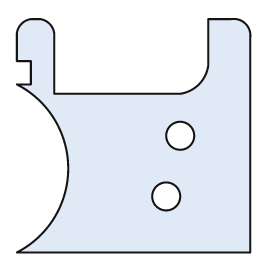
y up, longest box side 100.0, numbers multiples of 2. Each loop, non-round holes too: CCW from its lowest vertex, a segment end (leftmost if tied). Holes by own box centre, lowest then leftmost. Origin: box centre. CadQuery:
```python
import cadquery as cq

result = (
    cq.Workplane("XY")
    .moveTo(-50.0, -50.0)
    .lineTo(50.0, -50.0)
    .lineTo(50.0, 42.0)
    .threePointArc((48.0, 48.0), (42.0, 50.0))
    .lineTo(32.0, 50.0)
    .lineTo(32.0, 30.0)
    .threePointArc((28.0, 22.0), (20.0, 18.0))
    .lineTo(-34.0, 18.0)
    .lineTo(-34.0, 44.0)
    .threePointArc((-36.0, 48.0), (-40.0, 50.0))
    .lineTo(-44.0, 50.0)
    .threePointArc((-48.0, 48.0), (-50.0, 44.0))
    .lineTo(-50.0, 32.0)
    .lineTo(-44.0, 32.0)
    .lineTo(-44.0, 22.0)
    .lineTo(-50.0, 22.0)
    .threePointArc((-28.0, -14.0), (-50.0, -50.0))
    .close()
    .moveTo(14.0, -26.0)
    .circle(6.0)
    .moveTo(20.0, 0.0)
    .circle(6.0)
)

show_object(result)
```